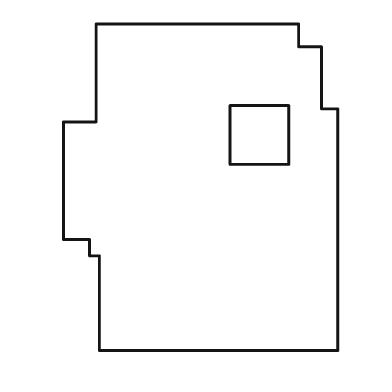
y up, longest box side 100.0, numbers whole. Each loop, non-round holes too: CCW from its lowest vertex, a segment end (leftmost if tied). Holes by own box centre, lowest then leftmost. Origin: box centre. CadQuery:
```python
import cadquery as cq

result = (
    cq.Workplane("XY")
    .moveTo(-31.0, -50.0)
    .lineTo(42.0, -50.0)
    .lineTo(42.0, 24.0)
    .lineTo(37.0, 24.0)
    .lineTo(37.0, 43.0)
    .lineTo(30.0, 43.0)
    .lineTo(30.0, 50.0)
    .lineTo(-32.0, 50.0)
    .lineTo(-32.0, 20.0)
    .lineTo(-42.0, 20.0)
    .lineTo(-42.0, -16.0)
    .lineTo(-34.0, -16.0)
    .lineTo(-34.0, -21.0)
    .lineTo(-31.0, -21.0)
    .close()
    .moveTo(9.0, 7.0)
    .lineTo(27.0, 7.0)
    .lineTo(27.0, 25.0)
    .lineTo(9.0, 25.0)
    .close()
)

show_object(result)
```